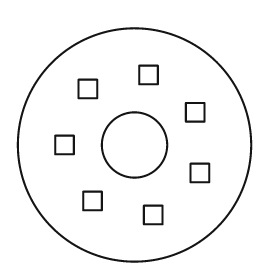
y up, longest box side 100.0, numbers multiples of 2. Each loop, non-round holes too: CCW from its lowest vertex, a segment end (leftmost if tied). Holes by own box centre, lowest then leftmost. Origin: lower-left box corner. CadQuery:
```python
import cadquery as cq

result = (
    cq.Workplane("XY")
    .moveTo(50.0, 50.0)
    .circle(50.0)
    .moveTo(54.0, 16.0)
    .lineTo(62.0, 16.0)
    .lineTo(62.0, 24.0)
    .lineTo(54.0, 24.0)
    .close()
    .moveTo(28.0, 22.0)
    .lineTo(36.0, 22.0)
    .lineTo(36.0, 30.0)
    .lineTo(28.0, 30.0)
    .close()
    .moveTo(74.0, 34.0)
    .lineTo(82.0, 34.0)
    .lineTo(82.0, 42.0)
    .lineTo(74.0, 42.0)
    .close()
    .moveTo(16.0, 46.0)
    .lineTo(24.0, 46.0)
    .lineTo(24.0, 54.0)
    .lineTo(16.0, 54.0)
    .close()
    .moveTo(50.0, 50.0)
    .circle(14.0)
    .moveTo(72.0, 60.0)
    .lineTo(80.0, 60.0)
    .lineTo(80.0, 68.0)
    .lineTo(72.0, 68.0)
    .close()
    .moveTo(26.0, 70.0)
    .lineTo(34.0, 70.0)
    .lineTo(34.0, 78.0)
    .lineTo(26.0, 78.0)
    .close()
    .moveTo(52.0, 76.0)
    .lineTo(60.0, 76.0)
    .lineTo(60.0, 84.0)
    .lineTo(52.0, 84.0)
    .close()
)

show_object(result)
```